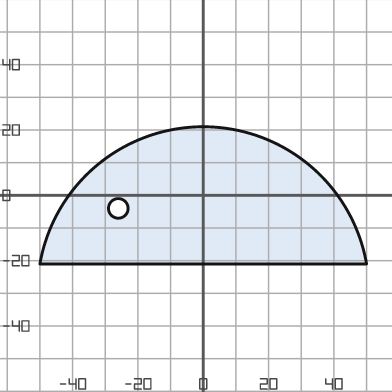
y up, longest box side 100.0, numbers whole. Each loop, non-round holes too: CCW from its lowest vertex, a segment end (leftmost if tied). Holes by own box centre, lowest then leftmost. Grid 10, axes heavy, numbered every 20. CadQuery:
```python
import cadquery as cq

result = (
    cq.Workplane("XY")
    .moveTo(-50.0, -21.0)
    .lineTo(50.0, -21.0)
    .threePointArc((0.0, 21.0), (-50.0, -21.0))
    .close()
    .moveTo(-26.0, -4.0)
    .circle(3.0)
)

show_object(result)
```